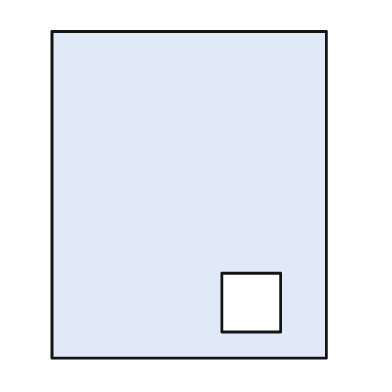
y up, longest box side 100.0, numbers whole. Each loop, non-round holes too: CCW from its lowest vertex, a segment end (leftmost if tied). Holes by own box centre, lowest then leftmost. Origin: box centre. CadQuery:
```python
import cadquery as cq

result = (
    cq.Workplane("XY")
    .moveTo(-42.0, -50.0)
    .lineTo(42.0, -50.0)
    .lineTo(42.0, 50.0)
    .lineTo(-42.0, 50.0)
    .close()
    .moveTo(10.0, -42.0)
    .lineTo(28.0, -42.0)
    .lineTo(28.0, -24.0)
    .lineTo(10.0, -24.0)
    .close()
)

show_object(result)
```